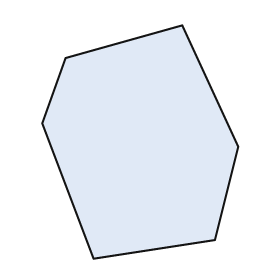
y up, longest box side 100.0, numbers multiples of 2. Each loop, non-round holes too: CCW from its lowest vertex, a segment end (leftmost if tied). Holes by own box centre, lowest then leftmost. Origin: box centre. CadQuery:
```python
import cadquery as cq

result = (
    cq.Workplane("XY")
    .moveTo(-20.0, -50.0)
    .lineTo(32.0, -42.0)
    .lineTo(42.0, -2.0)
    .lineTo(18.0, 50.0)
    .lineTo(-32.0, 36.0)
    .lineTo(-42.0, 8.0)
    .close()
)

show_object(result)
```